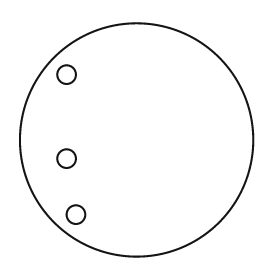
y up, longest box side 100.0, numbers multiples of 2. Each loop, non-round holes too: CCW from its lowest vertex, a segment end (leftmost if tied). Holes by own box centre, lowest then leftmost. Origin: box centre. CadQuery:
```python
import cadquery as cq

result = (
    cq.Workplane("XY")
    .moveTo(0.0, 0.0)
    .circle(50.0)
    .moveTo(-26.0, -32.0)
    .circle(4.0)
    .moveTo(-30.0, -8.0)
    .circle(4.0)
    .moveTo(-30.0, 28.0)
    .circle(4.0)
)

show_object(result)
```